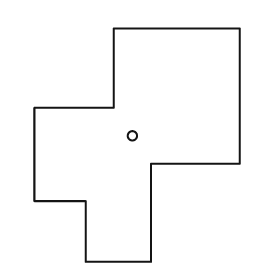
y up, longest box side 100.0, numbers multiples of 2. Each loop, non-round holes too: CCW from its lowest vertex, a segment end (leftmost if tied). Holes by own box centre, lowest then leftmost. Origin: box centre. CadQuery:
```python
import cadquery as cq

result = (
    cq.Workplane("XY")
    .moveTo(-22.0, -50.0)
    .lineTo(6.0, -50.0)
    .lineTo(6.0, -8.0)
    .lineTo(44.0, -8.0)
    .lineTo(44.0, 50.0)
    .lineTo(-10.0, 50.0)
    .lineTo(-10.0, 16.0)
    .lineTo(-44.0, 16.0)
    .lineTo(-44.0, -24.0)
    .lineTo(-22.0, -24.0)
    .close()
    .moveTo(-2.0, 4.0)
    .circle(2.0)
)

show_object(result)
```